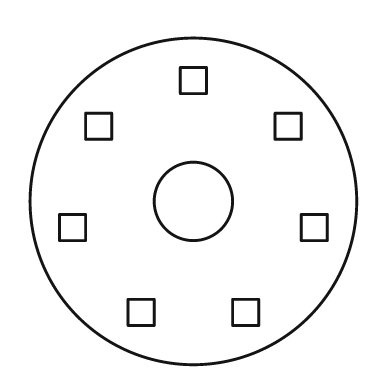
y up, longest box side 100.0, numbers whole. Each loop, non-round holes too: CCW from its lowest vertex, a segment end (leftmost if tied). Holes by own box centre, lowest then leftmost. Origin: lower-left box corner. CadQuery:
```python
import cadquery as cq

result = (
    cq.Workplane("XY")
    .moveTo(50.0, 50.0)
    .circle(50.0)
    .moveTo(30.0, 12.0)
    .lineTo(38.0, 12.0)
    .lineTo(38.0, 20.0)
    .lineTo(30.0, 20.0)
    .close()
    .moveTo(62.0, 12.0)
    .lineTo(70.0, 12.0)
    .lineTo(70.0, 20.0)
    .lineTo(62.0, 20.0)
    .close()
    .moveTo(9.0, 38.0)
    .lineTo(17.0, 38.0)
    .lineTo(17.0, 46.0)
    .lineTo(9.0, 46.0)
    .close()
    .moveTo(83.0, 38.0)
    .lineTo(91.0, 38.0)
    .lineTo(91.0, 46.0)
    .lineTo(83.0, 46.0)
    .close()
    .moveTo(50.0, 50.0)
    .circle(12.0)
    .moveTo(17.0, 69.0)
    .lineTo(25.0, 69.0)
    .lineTo(25.0, 77.0)
    .lineTo(17.0, 77.0)
    .close()
    .moveTo(75.0, 69.0)
    .lineTo(83.0, 69.0)
    .lineTo(83.0, 77.0)
    .lineTo(75.0, 77.0)
    .close()
    .moveTo(46.0, 83.0)
    .lineTo(54.0, 83.0)
    .lineTo(54.0, 91.0)
    .lineTo(46.0, 91.0)
    .close()
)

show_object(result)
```